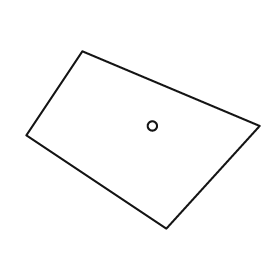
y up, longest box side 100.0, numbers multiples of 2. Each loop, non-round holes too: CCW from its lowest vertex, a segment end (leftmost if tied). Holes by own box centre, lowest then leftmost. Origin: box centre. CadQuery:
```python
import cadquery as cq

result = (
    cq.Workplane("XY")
    .moveTo(10.0, -38.0)
    .lineTo(50.0, 6.0)
    .lineTo(-26.0, 38.0)
    .lineTo(-50.0, 2.0)
    .close()
    .moveTo(4.0, 6.0)
    .circle(2.0)
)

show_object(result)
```